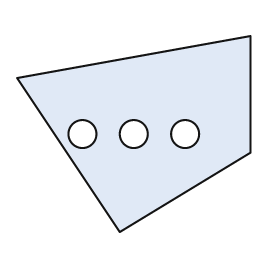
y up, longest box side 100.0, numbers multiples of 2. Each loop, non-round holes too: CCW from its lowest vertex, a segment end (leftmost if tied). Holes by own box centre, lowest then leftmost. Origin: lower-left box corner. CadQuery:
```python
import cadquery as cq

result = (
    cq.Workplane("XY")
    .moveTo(44.0, 0.0)
    .lineTo(100.0, 34.0)
    .lineTo(100.0, 84.0)
    .lineTo(0.0, 66.0)
    .close()
    .moveTo(28.0, 42.0)
    .circle(6.0)
    .moveTo(50.0, 42.0)
    .circle(6.0)
    .moveTo(72.0, 42.0)
    .circle(6.0)
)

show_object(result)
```